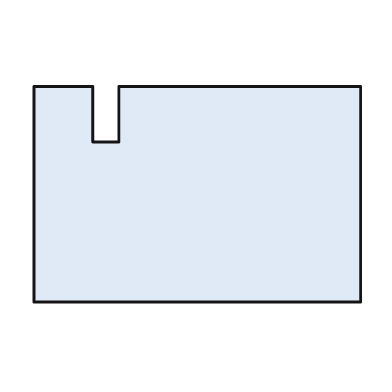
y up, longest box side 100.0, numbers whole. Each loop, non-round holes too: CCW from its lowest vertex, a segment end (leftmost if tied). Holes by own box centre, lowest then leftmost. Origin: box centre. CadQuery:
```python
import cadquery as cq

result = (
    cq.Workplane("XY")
    .moveTo(-50.0, -33.0)
    .lineTo(50.0, -33.0)
    .lineTo(50.0, 33.0)
    .lineTo(-24.0, 33.0)
    .lineTo(-24.0, 16.0)
    .lineTo(-32.0, 16.0)
    .lineTo(-32.0, 33.0)
    .lineTo(-50.0, 33.0)
    .close()
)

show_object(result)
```